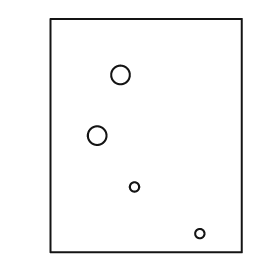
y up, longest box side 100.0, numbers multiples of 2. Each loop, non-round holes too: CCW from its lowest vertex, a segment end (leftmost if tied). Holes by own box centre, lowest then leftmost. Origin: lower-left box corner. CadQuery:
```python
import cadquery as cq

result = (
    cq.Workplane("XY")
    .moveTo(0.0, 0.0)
    .lineTo(82.0, 0.0)
    .lineTo(82.0, 100.0)
    .lineTo(0.0, 100.0)
    .close()
    .moveTo(64.0, 8.0)
    .circle(2.0)
    .moveTo(36.0, 28.0)
    .circle(2.0)
    .moveTo(20.0, 50.0)
    .circle(4.0)
    .moveTo(30.0, 76.0)
    .circle(4.0)
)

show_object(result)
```